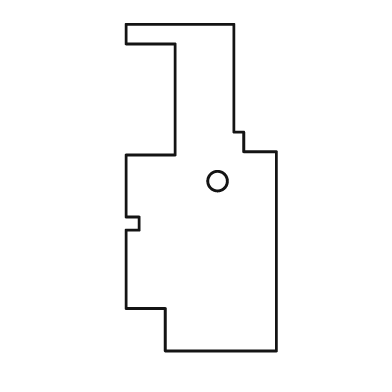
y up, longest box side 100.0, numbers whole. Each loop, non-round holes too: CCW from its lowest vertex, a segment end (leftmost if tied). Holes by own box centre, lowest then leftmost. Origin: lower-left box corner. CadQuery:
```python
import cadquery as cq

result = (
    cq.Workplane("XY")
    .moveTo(12.0, 0.0)
    .lineTo(46.0, 0.0)
    .lineTo(46.0, 61.0)
    .lineTo(36.0, 61.0)
    .lineTo(36.0, 67.0)
    .lineTo(33.0, 67.0)
    .lineTo(33.0, 100.0)
    .lineTo(0.0, 100.0)
    .lineTo(0.0, 94.0)
    .lineTo(15.0, 94.0)
    .lineTo(15.0, 60.0)
    .lineTo(0.0, 60.0)
    .lineTo(0.0, 41.0)
    .lineTo(4.0, 41.0)
    .lineTo(4.0, 37.0)
    .lineTo(0.0, 37.0)
    .lineTo(0.0, 13.0)
    .lineTo(12.0, 13.0)
    .close()
    .moveTo(28.0, 52.0)
    .circle(3.0)
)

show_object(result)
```